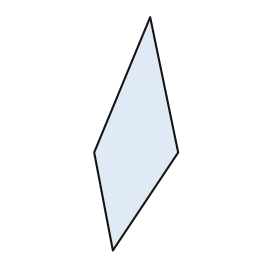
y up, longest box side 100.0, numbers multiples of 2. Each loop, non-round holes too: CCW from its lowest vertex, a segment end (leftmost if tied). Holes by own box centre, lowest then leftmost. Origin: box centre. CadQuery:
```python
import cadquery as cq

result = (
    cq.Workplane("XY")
    .moveTo(-10.0, -50.0)
    .lineTo(18.0, -8.0)
    .lineTo(6.0, 50.0)
    .lineTo(-18.0, -8.0)
    .close()
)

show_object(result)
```